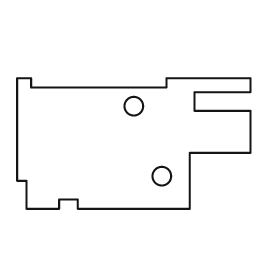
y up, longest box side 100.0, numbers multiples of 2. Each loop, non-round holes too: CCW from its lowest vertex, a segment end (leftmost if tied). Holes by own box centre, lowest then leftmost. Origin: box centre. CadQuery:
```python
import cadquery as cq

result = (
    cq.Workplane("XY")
    .moveTo(-46.0, -28.0)
    .lineTo(-32.0, -28.0)
    .lineTo(-32.0, -24.0)
    .lineTo(-24.0, -24.0)
    .lineTo(-24.0, -28.0)
    .lineTo(24.0, -28.0)
    .lineTo(24.0, -4.0)
    .lineTo(50.0, -4.0)
    .lineTo(50.0, 14.0)
    .lineTo(26.0, 14.0)
    .lineTo(26.0, 22.0)
    .lineTo(50.0, 22.0)
    .lineTo(50.0, 28.0)
    .lineTo(14.0, 28.0)
    .lineTo(14.0, 24.0)
    .lineTo(-44.0, 24.0)
    .lineTo(-44.0, 28.0)
    .lineTo(-50.0, 28.0)
    .lineTo(-50.0, -16.0)
    .lineTo(-46.0, -16.0)
    .close()
    .moveTo(12.0, -14.0)
    .circle(4.0)
    .moveTo(0.0, 16.0)
    .circle(4.0)
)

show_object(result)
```